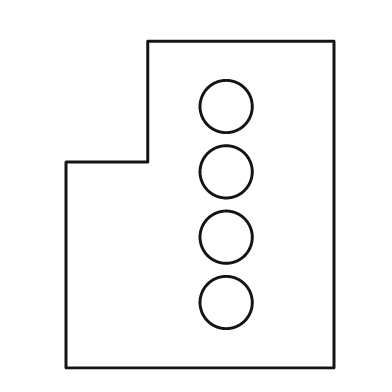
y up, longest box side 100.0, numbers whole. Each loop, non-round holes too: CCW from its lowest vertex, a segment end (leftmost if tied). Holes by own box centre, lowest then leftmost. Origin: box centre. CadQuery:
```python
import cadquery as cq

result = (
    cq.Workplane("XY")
    .moveTo(-41.0, -50.0)
    .lineTo(41.0, -50.0)
    .lineTo(41.0, 50.0)
    .lineTo(-16.0, 50.0)
    .lineTo(-16.0, 13.0)
    .lineTo(-41.0, 13.0)
    .close()
    .moveTo(8.0, -30.0)
    .circle(8.0)
    .moveTo(8.0, -10.0)
    .circle(8.0)
    .moveTo(8.0, 10.0)
    .circle(8.0)
    .moveTo(8.0, 30.0)
    .circle(8.0)
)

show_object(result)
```